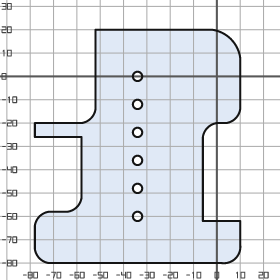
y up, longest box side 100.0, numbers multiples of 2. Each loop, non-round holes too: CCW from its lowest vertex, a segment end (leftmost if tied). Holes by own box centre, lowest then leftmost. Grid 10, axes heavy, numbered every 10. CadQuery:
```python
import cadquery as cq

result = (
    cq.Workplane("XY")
    .moveTo(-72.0, -80.0)
    .lineTo(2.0, -80.0)
    .threePointArc((8.0, -78.0), (10.0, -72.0))
    .lineTo(10.0, -62.0)
    .lineTo(-6.0, -62.0)
    .lineTo(-6.0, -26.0)
    .threePointArc((-4.0, -22.0), (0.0, -20.0))
    .lineTo(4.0, -20.0)
    .threePointArc((8.0, -18.0), (10.0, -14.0))
    .lineTo(10.0, 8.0)
    .threePointArc((6.0, 16.0), (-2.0, 20.0))
    .lineTo(-52.0, 20.0)
    .lineTo(-52.0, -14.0)
    .threePointArc((-54.0, -18.0), (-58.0, -20.0))
    .lineTo(-78.0, -20.0)
    .lineTo(-78.0, -26.0)
    .lineTo(-58.0, -26.0)
    .lineTo(-58.0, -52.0)
    .threePointArc((-60.0, -56.0), (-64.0, -58.0))
    .lineTo(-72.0, -58.0)
    .threePointArc((-76.0, -60.0), (-78.0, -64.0))
    .lineTo(-78.0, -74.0)
    .threePointArc((-76.0, -78.0), (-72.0, -80.0))
    .close()
    .moveTo(-34.0, -60.0)
    .circle(2.0)
    .moveTo(-34.0, -48.0)
    .circle(2.0)
    .moveTo(-34.0, -36.0)
    .circle(2.0)
    .moveTo(-34.0, -24.0)
    .circle(2.0)
    .moveTo(-34.0, -12.0)
    .circle(2.0)
    .moveTo(-34.0, 0.0)
    .circle(2.0)
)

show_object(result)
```